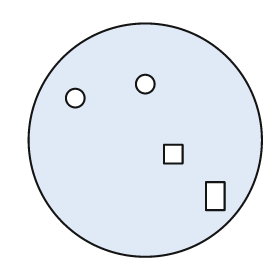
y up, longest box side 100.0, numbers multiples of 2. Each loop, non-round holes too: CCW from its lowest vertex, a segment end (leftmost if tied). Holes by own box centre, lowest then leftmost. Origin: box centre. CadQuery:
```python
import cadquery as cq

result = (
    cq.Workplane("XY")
    .moveTo(0.0, 0.0)
    .circle(50.0)
    .moveTo(26.0, -30.0)
    .lineTo(34.0, -30.0)
    .lineTo(34.0, -18.0)
    .lineTo(26.0, -18.0)
    .close()
    .moveTo(8.0, -10.0)
    .lineTo(16.0, -10.0)
    .lineTo(16.0, -2.0)
    .lineTo(8.0, -2.0)
    .close()
    .moveTo(-30.0, 18.0)
    .circle(4.0)
    .moveTo(0.0, 24.0)
    .circle(4.0)
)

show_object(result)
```